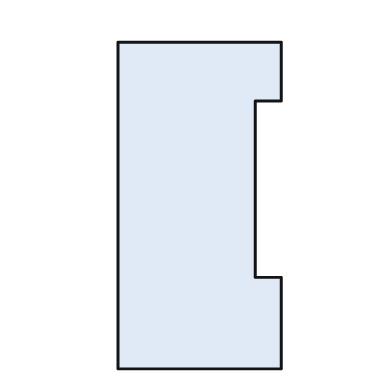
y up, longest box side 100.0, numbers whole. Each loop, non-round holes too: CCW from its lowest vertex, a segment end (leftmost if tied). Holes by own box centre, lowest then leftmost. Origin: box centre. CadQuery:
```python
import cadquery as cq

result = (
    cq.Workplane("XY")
    .moveTo(-25.0, -50.0)
    .lineTo(25.0, -50.0)
    .lineTo(25.0, -22.0)
    .lineTo(17.0, -22.0)
    .lineTo(17.0, 32.0)
    .lineTo(25.0, 32.0)
    .lineTo(25.0, 50.0)
    .lineTo(-25.0, 50.0)
    .close()
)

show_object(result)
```